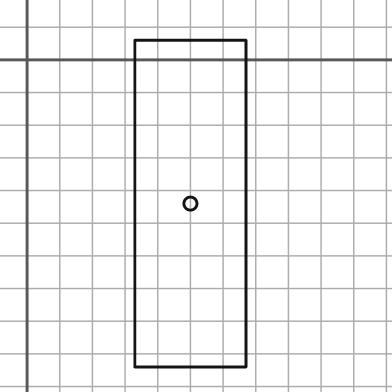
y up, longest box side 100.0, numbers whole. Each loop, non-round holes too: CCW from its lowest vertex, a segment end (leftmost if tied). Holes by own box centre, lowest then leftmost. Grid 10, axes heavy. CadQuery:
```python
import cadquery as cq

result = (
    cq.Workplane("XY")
    .moveTo(33.0, -94.0)
    .lineTo(67.0, -94.0)
    .lineTo(67.0, 6.0)
    .lineTo(33.0, 6.0)
    .close()
    .moveTo(50.0, -44.0)
    .circle(2.0)
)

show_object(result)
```